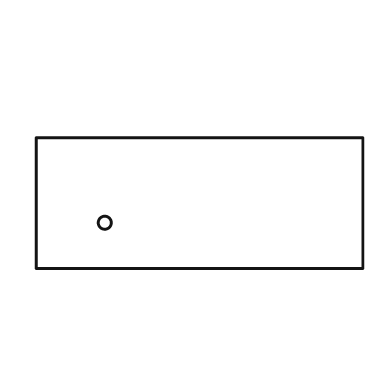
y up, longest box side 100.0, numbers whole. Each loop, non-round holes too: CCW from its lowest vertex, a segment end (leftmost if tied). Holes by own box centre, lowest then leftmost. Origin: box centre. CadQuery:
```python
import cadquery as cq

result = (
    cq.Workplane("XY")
    .moveTo(-50.0, -20.0)
    .lineTo(50.0, -20.0)
    .lineTo(50.0, 20.0)
    .lineTo(-50.0, 20.0)
    .close()
    .moveTo(-29.0, -6.0)
    .circle(2.0)
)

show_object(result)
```